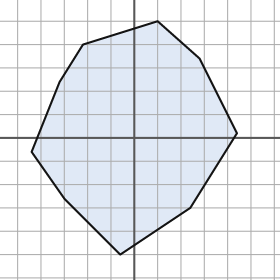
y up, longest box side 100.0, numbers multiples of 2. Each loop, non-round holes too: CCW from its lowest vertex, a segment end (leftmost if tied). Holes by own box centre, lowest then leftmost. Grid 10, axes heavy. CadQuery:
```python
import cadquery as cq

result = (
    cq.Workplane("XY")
    .moveTo(-6.0, -50.0)
    .lineTo(24.0, -30.0)
    .lineTo(44.0, 2.0)
    .lineTo(28.0, 34.0)
    .lineTo(10.0, 50.0)
    .lineTo(-22.0, 40.0)
    .lineTo(-32.0, 24.0)
    .lineTo(-44.0, -6.0)
    .lineTo(-30.0, -26.0)
    .close()
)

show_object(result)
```